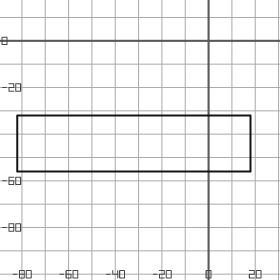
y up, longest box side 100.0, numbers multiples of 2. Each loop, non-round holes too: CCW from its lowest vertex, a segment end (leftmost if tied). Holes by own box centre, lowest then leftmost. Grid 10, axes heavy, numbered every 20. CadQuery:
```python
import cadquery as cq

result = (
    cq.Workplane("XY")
    .moveTo(-82.0, -56.0)
    .lineTo(18.0, -56.0)
    .lineTo(18.0, -32.0)
    .lineTo(-82.0, -32.0)
    .close()
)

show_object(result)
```